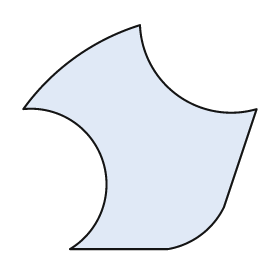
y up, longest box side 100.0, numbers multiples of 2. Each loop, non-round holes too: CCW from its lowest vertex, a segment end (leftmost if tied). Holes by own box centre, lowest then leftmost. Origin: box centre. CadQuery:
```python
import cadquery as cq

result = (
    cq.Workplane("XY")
    .moveTo(-30.0, -48.0)
    .lineTo(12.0, -48.0)
    .threePointArc((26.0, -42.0), (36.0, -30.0))
    .lineTo(50.0, 12.0)
    .threePointArc((16.0, 18.0), (0.0, 48.0))
    .threePointArc((-28.0, 34.0), (-50.0, 12.0))
    .threePointArc((-16.0, -10.0), (-30.0, -48.0))
    .close()
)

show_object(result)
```